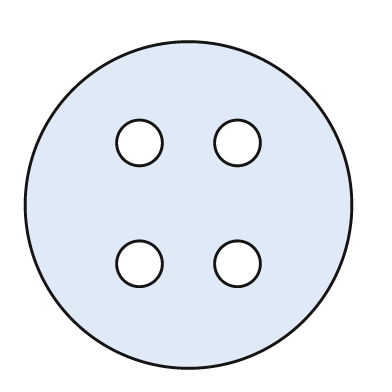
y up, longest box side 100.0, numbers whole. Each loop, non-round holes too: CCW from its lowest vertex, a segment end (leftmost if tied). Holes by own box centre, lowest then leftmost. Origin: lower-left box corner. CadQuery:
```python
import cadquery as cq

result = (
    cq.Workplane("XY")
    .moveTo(50.0, 50.0)
    .circle(50.0)
    .moveTo(35.0, 32.0)
    .circle(7.0)
    .moveTo(65.0, 32.0)
    .circle(7.0)
    .moveTo(35.0, 69.0)
    .circle(7.0)
    .moveTo(65.0, 69.0)
    .circle(7.0)
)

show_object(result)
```